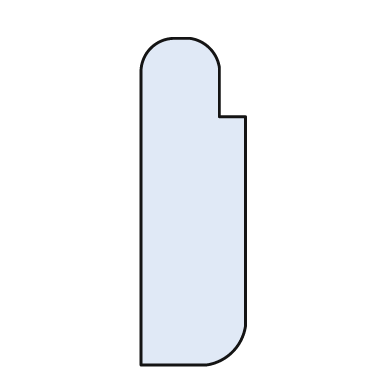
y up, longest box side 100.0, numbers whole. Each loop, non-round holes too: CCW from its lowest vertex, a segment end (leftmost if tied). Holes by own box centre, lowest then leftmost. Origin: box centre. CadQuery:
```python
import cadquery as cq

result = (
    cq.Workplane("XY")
    .moveTo(-16.0, -50.0)
    .lineTo(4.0, -50.0)
    .threePointArc((12.0, -46.0), (16.0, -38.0))
    .lineTo(16.0, 26.0)
    .lineTo(8.0, 26.0)
    .lineTo(8.0, 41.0)
    .threePointArc((5.0, 47.0), (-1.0, 50.0))
    .lineTo(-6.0, 50.0)
    .threePointArc((-13.0, 47.0), (-16.0, 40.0))
    .close()
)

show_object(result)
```